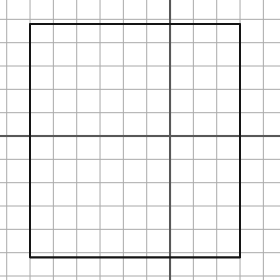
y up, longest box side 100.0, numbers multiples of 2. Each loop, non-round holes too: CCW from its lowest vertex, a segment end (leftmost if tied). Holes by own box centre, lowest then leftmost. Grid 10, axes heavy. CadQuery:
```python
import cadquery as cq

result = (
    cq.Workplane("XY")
    .moveTo(-60.0, -52.0)
    .lineTo(30.0, -52.0)
    .lineTo(30.0, 48.0)
    .lineTo(-60.0, 48.0)
    .close()
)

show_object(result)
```